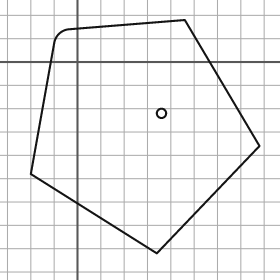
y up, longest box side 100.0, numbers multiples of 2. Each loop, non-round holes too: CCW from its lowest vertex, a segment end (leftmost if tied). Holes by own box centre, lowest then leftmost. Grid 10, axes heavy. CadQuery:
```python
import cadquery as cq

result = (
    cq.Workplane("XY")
    .moveTo(34.0, -82.0)
    .lineTo(78.0, -36.0)
    .lineTo(46.0, 18.0)
    .lineTo(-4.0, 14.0)
    .threePointArc((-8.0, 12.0), (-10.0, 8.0))
    .lineTo(-20.0, -48.0)
    .close()
    .moveTo(36.0, -22.0)
    .circle(2.0)
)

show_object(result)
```